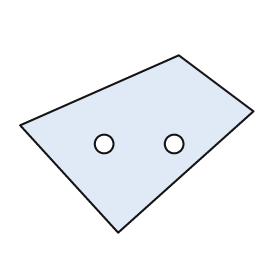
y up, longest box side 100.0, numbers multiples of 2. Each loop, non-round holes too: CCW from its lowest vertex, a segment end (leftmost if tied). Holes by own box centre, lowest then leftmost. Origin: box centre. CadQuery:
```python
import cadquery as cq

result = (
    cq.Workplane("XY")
    .moveTo(-8.0, -38.0)
    .lineTo(50.0, 14.0)
    .lineTo(18.0, 38.0)
    .lineTo(-50.0, 8.0)
    .close()
    .moveTo(-14.0, 0.0)
    .circle(4.0)
    .moveTo(16.0, 0.0)
    .circle(4.0)
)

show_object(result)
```